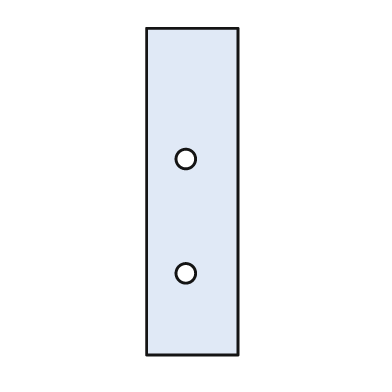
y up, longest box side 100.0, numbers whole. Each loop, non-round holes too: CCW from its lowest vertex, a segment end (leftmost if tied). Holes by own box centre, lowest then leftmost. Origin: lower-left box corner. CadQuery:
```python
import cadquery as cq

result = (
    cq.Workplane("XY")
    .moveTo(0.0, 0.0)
    .lineTo(28.0, 0.0)
    .lineTo(28.0, 100.0)
    .lineTo(0.0, 100.0)
    .close()
    .moveTo(12.0, 25.0)
    .circle(3.0)
    .moveTo(12.0, 60.0)
    .circle(3.0)
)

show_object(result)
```